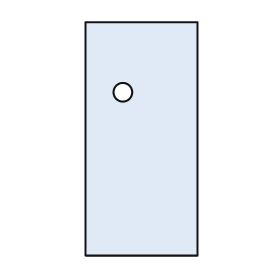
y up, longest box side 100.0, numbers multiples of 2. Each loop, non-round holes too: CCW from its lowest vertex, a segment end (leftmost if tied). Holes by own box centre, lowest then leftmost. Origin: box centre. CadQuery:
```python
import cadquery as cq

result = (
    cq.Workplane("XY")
    .moveTo(-24.0, -50.0)
    .lineTo(24.0, -50.0)
    .lineTo(24.0, 50.0)
    .lineTo(-24.0, 50.0)
    .close()
    .moveTo(-8.0, 20.0)
    .circle(4.0)
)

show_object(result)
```